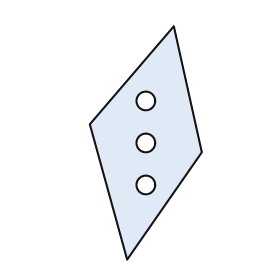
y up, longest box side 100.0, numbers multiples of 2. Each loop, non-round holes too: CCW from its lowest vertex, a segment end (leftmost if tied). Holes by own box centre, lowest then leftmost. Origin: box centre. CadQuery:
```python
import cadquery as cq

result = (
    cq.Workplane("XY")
    .moveTo(-8.0, -50.0)
    .lineTo(24.0, -4.0)
    .lineTo(12.0, 50.0)
    .lineTo(-24.0, 8.0)
    .close()
    .moveTo(0.0, -18.0)
    .circle(4.0)
    .moveTo(0.0, 0.0)
    .circle(4.0)
    .moveTo(0.0, 18.0)
    .circle(4.0)
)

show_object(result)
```